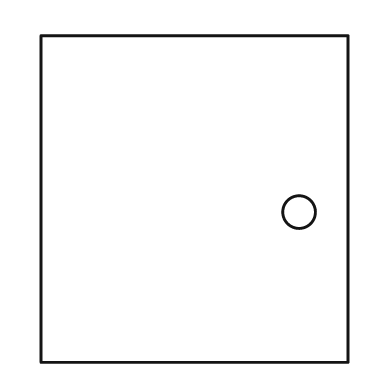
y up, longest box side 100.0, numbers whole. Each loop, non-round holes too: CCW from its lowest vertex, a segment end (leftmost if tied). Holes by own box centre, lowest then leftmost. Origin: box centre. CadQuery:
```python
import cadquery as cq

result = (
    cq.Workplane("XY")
    .moveTo(-47.0, -50.0)
    .lineTo(47.0, -50.0)
    .lineTo(47.0, 50.0)
    .lineTo(-47.0, 50.0)
    .close()
    .moveTo(32.0, -4.0)
    .circle(5.0)
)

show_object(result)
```